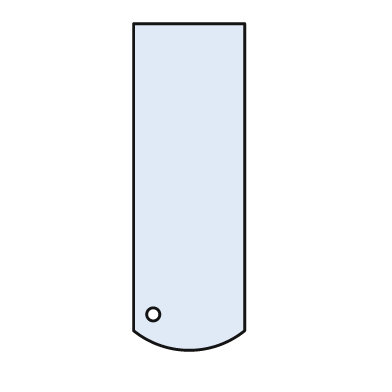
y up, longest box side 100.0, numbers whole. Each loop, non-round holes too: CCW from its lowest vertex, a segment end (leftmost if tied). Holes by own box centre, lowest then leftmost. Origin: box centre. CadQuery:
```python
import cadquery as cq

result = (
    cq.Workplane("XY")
    .moveTo(-17.0, -44.0)
    .threePointArc((0.0, -50.0), (17.0, -44.0))
    .lineTo(17.0, 50.0)
    .lineTo(-17.0, 50.0)
    .close()
    .moveTo(-11.0, -39.0)
    .circle(2.0)
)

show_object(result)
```